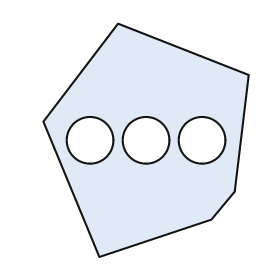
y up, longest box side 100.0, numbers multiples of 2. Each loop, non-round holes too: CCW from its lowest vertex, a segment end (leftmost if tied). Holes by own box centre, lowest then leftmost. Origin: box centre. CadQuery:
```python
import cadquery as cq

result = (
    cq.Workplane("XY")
    .moveTo(-20.0, -50.0)
    .lineTo(28.0, -34.0)
    .lineTo(38.0, -22.0)
    .lineTo(44.0, 28.0)
    .lineTo(-12.0, 50.0)
    .lineTo(-44.0, 8.0)
    .close()
    .moveTo(-24.0, 0.0)
    .circle(10.0)
    .moveTo(0.0, 0.0)
    .circle(10.0)
    .moveTo(24.0, 0.0)
    .circle(10.0)
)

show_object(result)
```